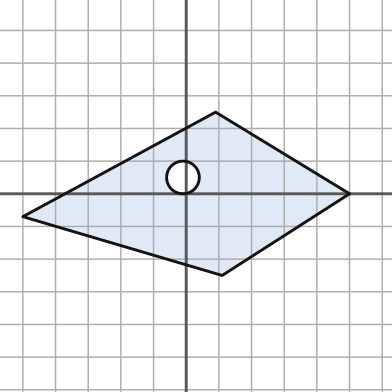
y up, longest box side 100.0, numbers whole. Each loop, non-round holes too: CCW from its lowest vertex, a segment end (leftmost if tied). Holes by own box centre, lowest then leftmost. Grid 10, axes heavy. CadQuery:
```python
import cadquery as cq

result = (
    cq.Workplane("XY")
    .moveTo(11.0, -25.0)
    .lineTo(50.0, 0.0)
    .lineTo(9.0, 25.0)
    .lineTo(-50.0, -7.0)
    .close()
    .moveTo(-1.0, 5.0)
    .circle(5.0)
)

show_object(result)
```